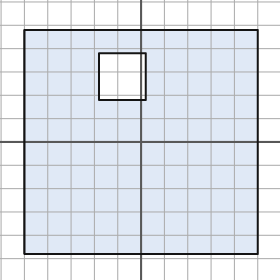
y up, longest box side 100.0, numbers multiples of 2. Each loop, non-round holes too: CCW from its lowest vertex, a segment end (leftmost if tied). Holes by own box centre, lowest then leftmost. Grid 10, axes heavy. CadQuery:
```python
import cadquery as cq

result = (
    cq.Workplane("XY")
    .moveTo(-50.0, -48.0)
    .lineTo(50.0, -48.0)
    .lineTo(50.0, 48.0)
    .lineTo(-50.0, 48.0)
    .close()
    .moveTo(-18.0, 18.0)
    .lineTo(2.0, 18.0)
    .lineTo(2.0, 38.0)
    .lineTo(-18.0, 38.0)
    .close()
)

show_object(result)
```